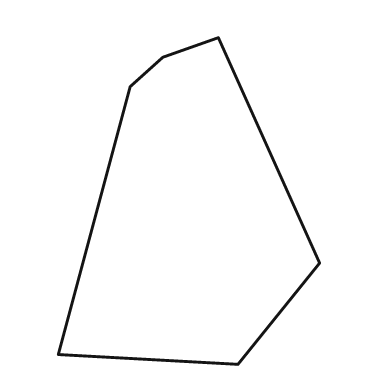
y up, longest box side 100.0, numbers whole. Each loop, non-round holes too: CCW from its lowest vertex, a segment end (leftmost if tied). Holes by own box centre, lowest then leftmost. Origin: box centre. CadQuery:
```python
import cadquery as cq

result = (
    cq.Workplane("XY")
    .moveTo(15.0, -50.0)
    .lineTo(40.0, -19.0)
    .lineTo(9.0, 50.0)
    .lineTo(-8.0, 44.0)
    .lineTo(-18.0, 35.0)
    .lineTo(-40.0, -47.0)
    .close()
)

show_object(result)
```